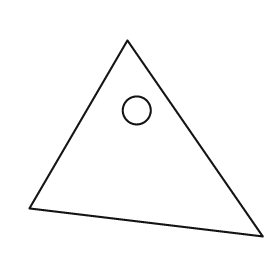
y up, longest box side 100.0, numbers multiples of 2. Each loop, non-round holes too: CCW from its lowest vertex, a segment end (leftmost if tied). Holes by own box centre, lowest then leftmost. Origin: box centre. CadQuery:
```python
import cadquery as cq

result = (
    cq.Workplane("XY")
    .moveTo(50.0, -42.0)
    .lineTo(-8.0, 42.0)
    .lineTo(-50.0, -30.0)
    .close()
    .moveTo(-4.0, 12.0)
    .circle(6.0)
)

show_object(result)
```